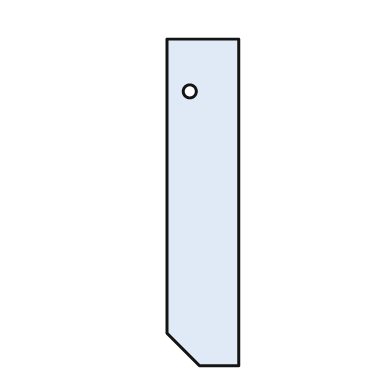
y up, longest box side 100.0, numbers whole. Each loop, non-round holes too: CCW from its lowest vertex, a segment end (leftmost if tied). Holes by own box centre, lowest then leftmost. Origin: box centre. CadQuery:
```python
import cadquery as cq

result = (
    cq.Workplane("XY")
    .moveTo(-1.0, -50.0)
    .lineTo(11.0, -50.0)
    .lineTo(11.0, 50.0)
    .lineTo(-11.0, 50.0)
    .lineTo(-11.0, -40.0)
    .close()
    .moveTo(-4.0, 34.0)
    .circle(2.0)
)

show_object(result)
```